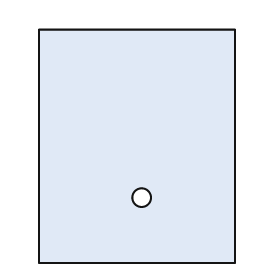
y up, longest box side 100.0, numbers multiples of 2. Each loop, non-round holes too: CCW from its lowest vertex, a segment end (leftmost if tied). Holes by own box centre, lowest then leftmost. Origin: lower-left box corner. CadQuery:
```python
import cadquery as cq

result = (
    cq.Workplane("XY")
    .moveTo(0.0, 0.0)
    .lineTo(84.0, 0.0)
    .lineTo(84.0, 100.0)
    .lineTo(0.0, 100.0)
    .close()
    .moveTo(44.0, 28.0)
    .circle(4.0)
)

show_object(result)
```